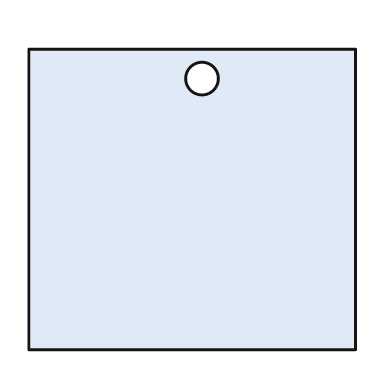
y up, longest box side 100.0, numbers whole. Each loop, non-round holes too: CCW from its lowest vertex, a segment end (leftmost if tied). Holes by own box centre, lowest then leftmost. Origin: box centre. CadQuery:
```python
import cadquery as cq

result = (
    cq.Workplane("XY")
    .moveTo(-50.0, -46.0)
    .lineTo(50.0, -46.0)
    .lineTo(50.0, 46.0)
    .lineTo(-50.0, 46.0)
    .close()
    .moveTo(3.0, 37.0)
    .circle(5.0)
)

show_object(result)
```